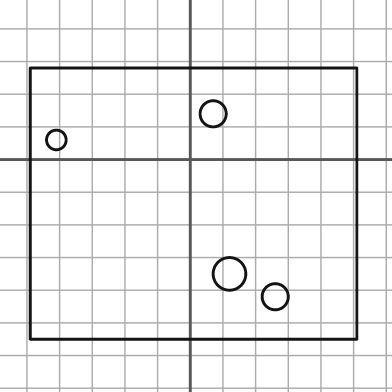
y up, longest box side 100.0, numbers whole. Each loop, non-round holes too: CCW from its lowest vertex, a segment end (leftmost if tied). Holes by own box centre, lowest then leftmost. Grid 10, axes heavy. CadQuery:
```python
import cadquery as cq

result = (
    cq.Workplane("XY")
    .moveTo(-49.0, -55.0)
    .lineTo(51.0, -55.0)
    .lineTo(51.0, 28.0)
    .lineTo(-49.0, 28.0)
    .close()
    .moveTo(26.0, -42.0)
    .circle(4.0)
    .moveTo(12.0, -35.0)
    .circle(5.0)
    .moveTo(-41.0, 6.0)
    .circle(3.0)
    .moveTo(7.0, 14.0)
    .circle(4.0)
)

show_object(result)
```